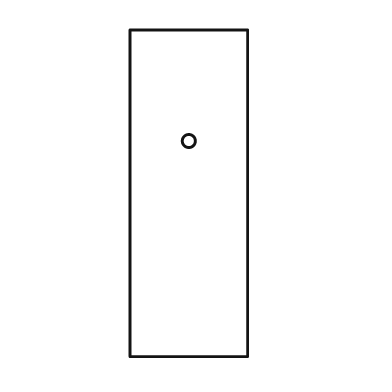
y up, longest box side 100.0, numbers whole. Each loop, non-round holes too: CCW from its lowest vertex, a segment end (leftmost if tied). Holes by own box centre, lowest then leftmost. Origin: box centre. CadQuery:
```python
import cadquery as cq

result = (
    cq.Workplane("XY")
    .moveTo(-18.0, -50.0)
    .lineTo(18.0, -50.0)
    .lineTo(18.0, 50.0)
    .lineTo(-18.0, 50.0)
    .close()
    .moveTo(0.0, 16.0)
    .circle(2.0)
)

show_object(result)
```